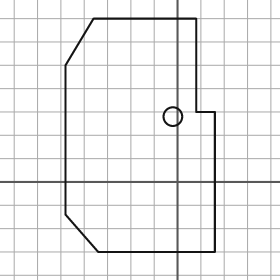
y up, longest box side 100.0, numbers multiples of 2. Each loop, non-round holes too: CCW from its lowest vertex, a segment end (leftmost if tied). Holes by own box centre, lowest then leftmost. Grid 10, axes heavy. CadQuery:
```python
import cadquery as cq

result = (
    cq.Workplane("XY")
    .moveTo(-34.0, -30.0)
    .lineTo(16.0, -30.0)
    .lineTo(16.0, 30.0)
    .lineTo(8.0, 30.0)
    .lineTo(8.0, 70.0)
    .lineTo(-36.0, 70.0)
    .lineTo(-48.0, 50.0)
    .lineTo(-48.0, -14.0)
    .close()
    .moveTo(-2.0, 28.0)
    .circle(4.0)
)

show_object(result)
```